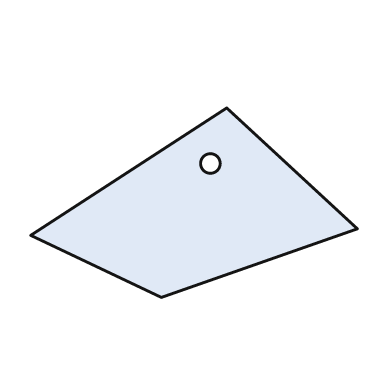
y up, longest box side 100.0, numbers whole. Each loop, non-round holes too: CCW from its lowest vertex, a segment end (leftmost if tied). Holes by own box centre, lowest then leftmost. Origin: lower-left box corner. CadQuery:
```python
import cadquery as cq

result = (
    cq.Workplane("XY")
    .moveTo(40.0, 0.0)
    .lineTo(100.0, 21.0)
    .lineTo(60.0, 58.0)
    .lineTo(0.0, 19.0)
    .close()
    .moveTo(55.0, 41.0)
    .circle(3.0)
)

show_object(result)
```